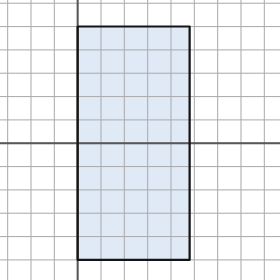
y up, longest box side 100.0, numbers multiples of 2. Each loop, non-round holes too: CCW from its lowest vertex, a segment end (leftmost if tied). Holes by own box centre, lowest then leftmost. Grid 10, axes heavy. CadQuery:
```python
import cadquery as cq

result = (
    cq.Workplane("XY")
    .moveTo(0.0, -50.0)
    .lineTo(48.0, -50.0)
    .lineTo(48.0, 50.0)
    .lineTo(0.0, 50.0)
    .close()
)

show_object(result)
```